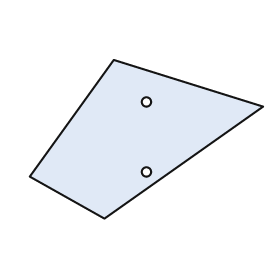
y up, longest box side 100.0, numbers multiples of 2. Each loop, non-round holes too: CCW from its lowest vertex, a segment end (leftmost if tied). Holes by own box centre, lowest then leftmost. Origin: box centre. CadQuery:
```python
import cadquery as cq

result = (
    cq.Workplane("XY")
    .moveTo(-18.0, -34.0)
    .lineTo(50.0, 14.0)
    .lineTo(-14.0, 34.0)
    .lineTo(-50.0, -16.0)
    .close()
    .moveTo(0.0, -14.0)
    .circle(2.0)
    .moveTo(0.0, 16.0)
    .circle(2.0)
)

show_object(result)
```